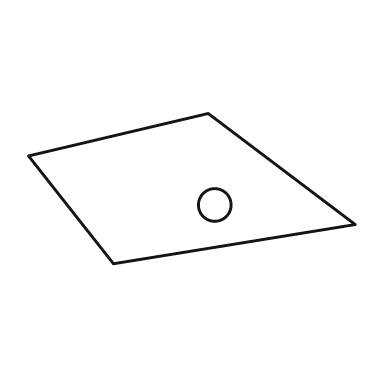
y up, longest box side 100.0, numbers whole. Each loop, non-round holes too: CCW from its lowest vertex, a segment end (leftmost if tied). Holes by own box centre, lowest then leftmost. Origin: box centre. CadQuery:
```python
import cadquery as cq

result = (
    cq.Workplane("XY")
    .moveTo(-24.0, -23.0)
    .lineTo(50.0, -11.0)
    .lineTo(5.0, 23.0)
    .lineTo(-50.0, 10.0)
    .close()
    .moveTo(7.0, -5.0)
    .circle(5.0)
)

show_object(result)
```